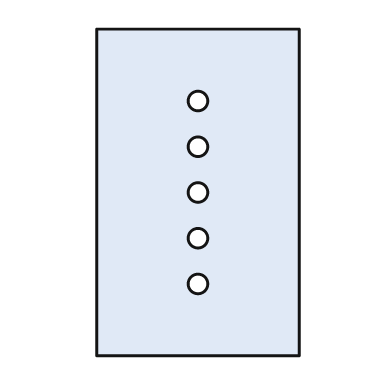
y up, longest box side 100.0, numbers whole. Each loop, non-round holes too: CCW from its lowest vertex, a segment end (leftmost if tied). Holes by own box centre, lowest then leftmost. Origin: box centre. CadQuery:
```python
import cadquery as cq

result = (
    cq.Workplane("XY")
    .moveTo(-31.0, -50.0)
    .lineTo(31.0, -50.0)
    .lineTo(31.0, 50.0)
    .lineTo(-31.0, 50.0)
    .close()
    .moveTo(0.0, -28.0)
    .circle(3.0)
    .moveTo(0.0, -14.0)
    .circle(3.0)
    .moveTo(0.0, 0.0)
    .circle(3.0)
    .moveTo(0.0, 14.0)
    .circle(3.0)
    .moveTo(0.0, 28.0)
    .circle(3.0)
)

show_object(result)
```